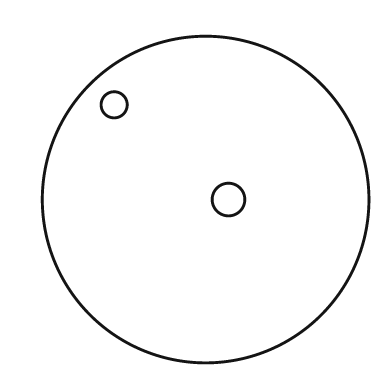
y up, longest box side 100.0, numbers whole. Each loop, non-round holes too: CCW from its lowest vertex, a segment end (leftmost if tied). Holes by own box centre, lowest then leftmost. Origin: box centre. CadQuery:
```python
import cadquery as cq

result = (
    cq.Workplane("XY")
    .moveTo(0.0, 0.0)
    .circle(50.0)
    .moveTo(7.0, 0.0)
    .circle(5.0)
    .moveTo(-28.0, 29.0)
    .circle(4.0)
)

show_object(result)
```